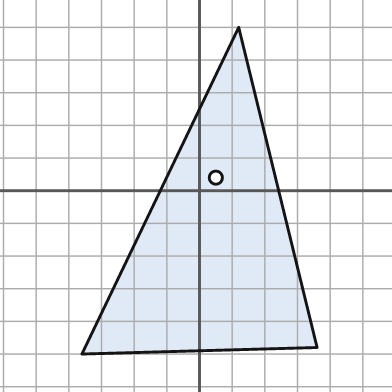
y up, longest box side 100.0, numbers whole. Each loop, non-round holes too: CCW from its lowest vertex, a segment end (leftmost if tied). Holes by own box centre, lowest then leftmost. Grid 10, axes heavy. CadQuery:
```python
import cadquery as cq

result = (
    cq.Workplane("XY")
    .moveTo(-36.0, -50.0)
    .lineTo(36.0, -48.0)
    .lineTo(12.0, 50.0)
    .close()
    .moveTo(5.0, 4.0)
    .circle(2.0)
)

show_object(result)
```